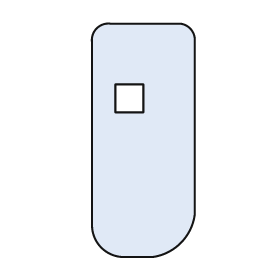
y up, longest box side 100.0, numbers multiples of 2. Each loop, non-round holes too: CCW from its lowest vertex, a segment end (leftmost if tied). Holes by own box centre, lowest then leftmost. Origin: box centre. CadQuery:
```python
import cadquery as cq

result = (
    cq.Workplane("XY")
    .moveTo(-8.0, -50.0)
    .lineTo(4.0, -50.0)
    .threePointArc((16.0, -44.0), (22.0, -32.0))
    .lineTo(22.0, 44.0)
    .threePointArc((20.0, 48.0), (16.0, 50.0))
    .lineTo(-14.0, 50.0)
    .threePointArc((-20.0, 48.0), (-22.0, 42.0))
    .lineTo(-22.0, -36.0)
    .threePointArc((-18.0, -46.0), (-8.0, -50.0))
    .close()
    .moveTo(-12.0, 12.0)
    .lineTo(0.0, 12.0)
    .lineTo(0.0, 24.0)
    .lineTo(-12.0, 24.0)
    .close()
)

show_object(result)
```